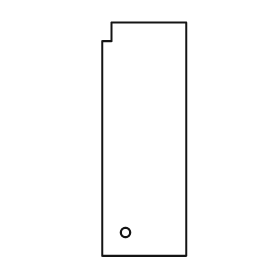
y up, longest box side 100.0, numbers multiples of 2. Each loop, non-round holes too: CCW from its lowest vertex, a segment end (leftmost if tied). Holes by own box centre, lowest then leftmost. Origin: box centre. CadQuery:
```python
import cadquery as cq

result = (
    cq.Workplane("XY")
    .moveTo(-18.0, -50.0)
    .lineTo(18.0, -50.0)
    .lineTo(18.0, 50.0)
    .lineTo(-14.0, 50.0)
    .lineTo(-14.0, 42.0)
    .lineTo(-18.0, 42.0)
    .close()
    .moveTo(-8.0, -40.0)
    .circle(2.0)
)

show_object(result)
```